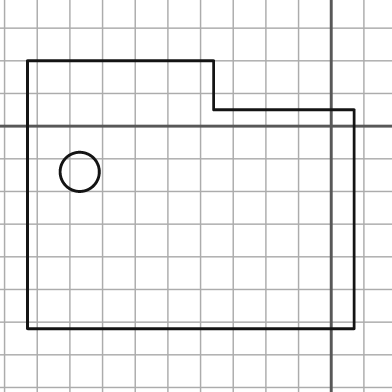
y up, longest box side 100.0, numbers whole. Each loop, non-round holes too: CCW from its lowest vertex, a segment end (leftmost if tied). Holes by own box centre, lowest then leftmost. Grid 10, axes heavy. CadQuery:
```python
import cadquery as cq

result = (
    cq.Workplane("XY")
    .moveTo(-93.0, -62.0)
    .lineTo(7.0, -62.0)
    .lineTo(7.0, 5.0)
    .lineTo(-36.0, 5.0)
    .lineTo(-36.0, 20.0)
    .lineTo(-93.0, 20.0)
    .close()
    .moveTo(-77.0, -14.0)
    .circle(6.0)
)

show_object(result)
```